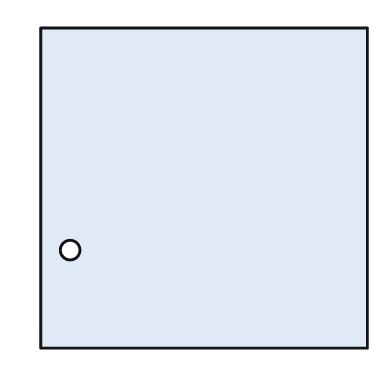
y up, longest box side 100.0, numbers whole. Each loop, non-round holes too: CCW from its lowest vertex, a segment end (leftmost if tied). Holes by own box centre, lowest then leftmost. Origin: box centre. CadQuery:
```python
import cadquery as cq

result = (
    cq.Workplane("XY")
    .moveTo(-50.0, -49.0)
    .lineTo(50.0, -49.0)
    .lineTo(50.0, 49.0)
    .lineTo(-50.0, 49.0)
    .close()
    .moveTo(-41.0, -19.0)
    .circle(3.0)
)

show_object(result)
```